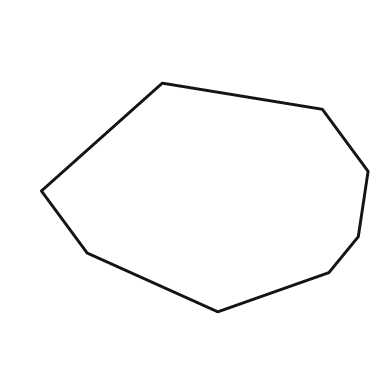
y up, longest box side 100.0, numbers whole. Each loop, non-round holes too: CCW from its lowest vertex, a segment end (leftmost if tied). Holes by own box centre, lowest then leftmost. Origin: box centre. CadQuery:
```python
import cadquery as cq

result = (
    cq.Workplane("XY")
    .moveTo(4.0, -35.0)
    .lineTo(38.0, -23.0)
    .lineTo(47.0, -12.0)
    .lineTo(50.0, 8.0)
    .lineTo(36.0, 27.0)
    .lineTo(-13.0, 35.0)
    .lineTo(-50.0, 2.0)
    .lineTo(-36.0, -17.0)
    .close()
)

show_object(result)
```